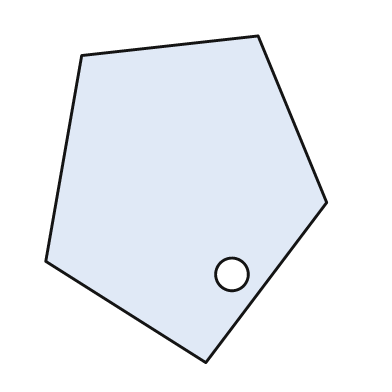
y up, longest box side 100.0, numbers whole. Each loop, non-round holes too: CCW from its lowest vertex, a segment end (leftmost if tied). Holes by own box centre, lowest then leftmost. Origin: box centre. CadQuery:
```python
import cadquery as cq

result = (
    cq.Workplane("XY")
    .moveTo(6.0, -50.0)
    .lineTo(43.0, -1.0)
    .lineTo(22.0, 50.0)
    .lineTo(-32.0, 44.0)
    .lineTo(-43.0, -19.0)
    .close()
    .moveTo(14.0, -23.0)
    .circle(5.0)
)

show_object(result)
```